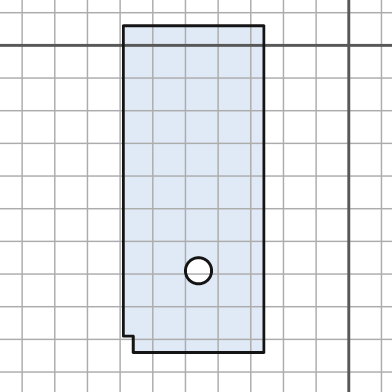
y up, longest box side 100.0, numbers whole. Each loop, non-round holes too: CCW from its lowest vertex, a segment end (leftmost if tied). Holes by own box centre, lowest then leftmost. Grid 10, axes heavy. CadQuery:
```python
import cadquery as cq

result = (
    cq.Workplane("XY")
    .moveTo(-66.0, -94.0)
    .lineTo(-26.0, -94.0)
    .lineTo(-26.0, 6.0)
    .lineTo(-69.0, 6.0)
    .lineTo(-69.0, -89.0)
    .lineTo(-66.0, -89.0)
    .close()
    .moveTo(-46.0, -69.0)
    .circle(4.0)
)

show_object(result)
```